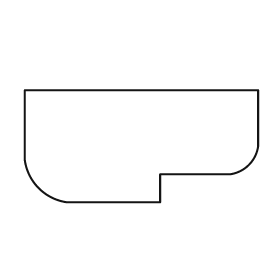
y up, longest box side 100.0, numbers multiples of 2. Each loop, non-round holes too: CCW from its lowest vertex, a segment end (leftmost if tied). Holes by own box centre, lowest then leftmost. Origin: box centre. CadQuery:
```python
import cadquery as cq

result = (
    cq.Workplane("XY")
    .moveTo(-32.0, -24.0)
    .lineTo(8.0, -24.0)
    .lineTo(8.0, -12.0)
    .lineTo(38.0, -12.0)
    .threePointArc((46.0, -8.0), (50.0, 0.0))
    .lineTo(50.0, 24.0)
    .lineTo(-50.0, 24.0)
    .lineTo(-50.0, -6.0)
    .threePointArc((-44.0, -18.0), (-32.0, -24.0))
    .close()
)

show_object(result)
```